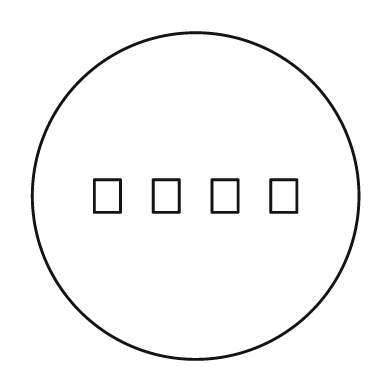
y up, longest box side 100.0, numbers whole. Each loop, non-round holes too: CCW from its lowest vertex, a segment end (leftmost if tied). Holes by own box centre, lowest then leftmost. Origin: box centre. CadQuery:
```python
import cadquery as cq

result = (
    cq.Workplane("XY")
    .moveTo(0.0, 0.0)
    .circle(50.0)
    .moveTo(-31.0, -5.0)
    .lineTo(-23.0, -5.0)
    .lineTo(-23.0, 5.0)
    .lineTo(-31.0, 5.0)
    .close()
    .moveTo(-13.0, -5.0)
    .lineTo(-5.0, -5.0)
    .lineTo(-5.0, 5.0)
    .lineTo(-13.0, 5.0)
    .close()
    .moveTo(5.0, -5.0)
    .lineTo(13.0, -5.0)
    .lineTo(13.0, 5.0)
    .lineTo(5.0, 5.0)
    .close()
    .moveTo(23.0, -5.0)
    .lineTo(31.0, -5.0)
    .lineTo(31.0, 5.0)
    .lineTo(23.0, 5.0)
    .close()
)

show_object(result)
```